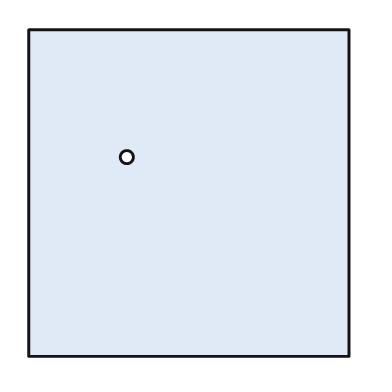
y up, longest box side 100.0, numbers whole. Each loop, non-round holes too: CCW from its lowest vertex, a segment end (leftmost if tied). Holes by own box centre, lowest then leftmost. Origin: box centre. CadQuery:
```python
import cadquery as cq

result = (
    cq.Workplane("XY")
    .moveTo(-49.0, -50.0)
    .lineTo(49.0, -50.0)
    .lineTo(49.0, 50.0)
    .lineTo(-49.0, 50.0)
    .close()
    .moveTo(-19.0, 11.0)
    .circle(2.0)
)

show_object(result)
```